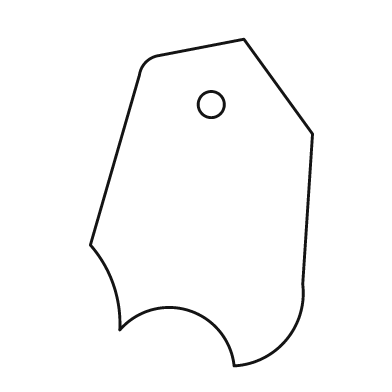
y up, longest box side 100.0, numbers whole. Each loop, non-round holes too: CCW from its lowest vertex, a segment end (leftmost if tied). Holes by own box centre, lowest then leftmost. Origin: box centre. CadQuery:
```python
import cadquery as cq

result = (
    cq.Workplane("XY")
    .moveTo(10.0, -50.0)
    .threePointArc((26.0, -42.0), (31.0, -25.0))
    .lineTo(34.0, 21.0)
    .lineTo(13.0, 50.0)
    .lineTo(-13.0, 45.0)
    .threePointArc((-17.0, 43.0), (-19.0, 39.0))
    .lineTo(-34.0, -13.0)
    .threePointArc((-27.0, -25.0), (-25.0, -39.0))
    .threePointArc((-4.0, -33.0), (10.0, -50.0))
    .close()
    .moveTo(3.0, 30.0)
    .circle(4.0)
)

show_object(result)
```